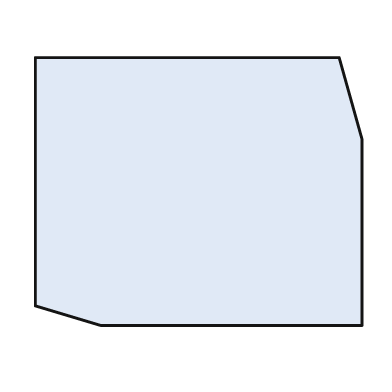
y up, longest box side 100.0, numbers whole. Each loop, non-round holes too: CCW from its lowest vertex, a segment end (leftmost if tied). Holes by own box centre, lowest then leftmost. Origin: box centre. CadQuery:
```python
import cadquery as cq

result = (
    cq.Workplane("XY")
    .moveTo(-30.0, -41.0)
    .lineTo(50.0, -41.0)
    .lineTo(50.0, 16.0)
    .lineTo(43.0, 41.0)
    .lineTo(-50.0, 41.0)
    .lineTo(-50.0, -35.0)
    .close()
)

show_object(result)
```